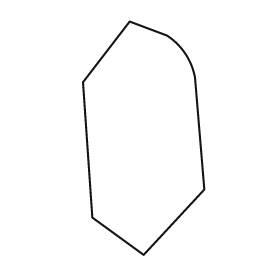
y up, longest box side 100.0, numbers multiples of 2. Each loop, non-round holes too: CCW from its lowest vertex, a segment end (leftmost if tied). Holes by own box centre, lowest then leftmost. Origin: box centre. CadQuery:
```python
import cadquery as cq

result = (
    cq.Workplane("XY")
    .moveTo(0.0, -50.0)
    .lineTo(26.0, -22.0)
    .lineTo(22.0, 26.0)
    .threePointArc((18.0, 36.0), (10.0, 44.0))
    .lineTo(-6.0, 50.0)
    .lineTo(-26.0, 24.0)
    .lineTo(-22.0, -34.0)
    .close()
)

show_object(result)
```